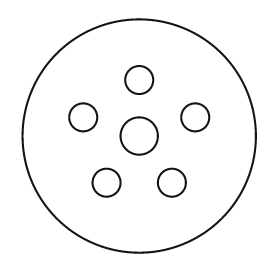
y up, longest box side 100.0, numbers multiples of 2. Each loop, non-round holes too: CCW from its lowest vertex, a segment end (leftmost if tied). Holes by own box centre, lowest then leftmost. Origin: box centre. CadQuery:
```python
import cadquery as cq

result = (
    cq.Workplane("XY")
    .moveTo(0.0, 0.0)
    .circle(50.0)
    .moveTo(-14.0, -20.0)
    .circle(6.0)
    .moveTo(14.0, -20.0)
    .circle(6.0)
    .moveTo(0.0, 0.0)
    .circle(8.0)
    .moveTo(-24.0, 8.0)
    .circle(6.0)
    .moveTo(24.0, 8.0)
    .circle(6.0)
    .moveTo(0.0, 24.0)
    .circle(6.0)
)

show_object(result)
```